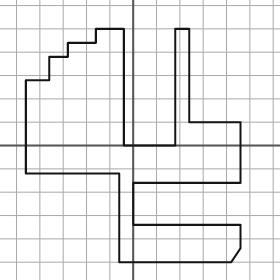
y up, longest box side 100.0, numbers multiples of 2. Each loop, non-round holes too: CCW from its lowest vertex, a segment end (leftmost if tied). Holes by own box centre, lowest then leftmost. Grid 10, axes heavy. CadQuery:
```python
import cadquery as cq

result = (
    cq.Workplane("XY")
    .moveTo(-6.0, -50.0)
    .lineTo(42.0, -50.0)
    .lineTo(46.0, -44.0)
    .lineTo(46.0, -34.0)
    .lineTo(0.0, -34.0)
    .lineTo(0.0, -16.0)
    .lineTo(46.0, -16.0)
    .lineTo(46.0, 10.0)
    .lineTo(24.0, 10.0)
    .lineTo(24.0, 50.0)
    .lineTo(18.0, 50.0)
    .lineTo(18.0, 0.0)
    .lineTo(-4.0, 0.0)
    .lineTo(-4.0, 50.0)
    .lineTo(-16.0, 50.0)
    .lineTo(-16.0, 44.0)
    .lineTo(-28.0, 44.0)
    .lineTo(-28.0, 38.0)
    .lineTo(-36.0, 38.0)
    .lineTo(-36.0, 28.0)
    .lineTo(-46.0, 28.0)
    .lineTo(-46.0, -12.0)
    .lineTo(-6.0, -12.0)
    .close()
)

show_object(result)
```